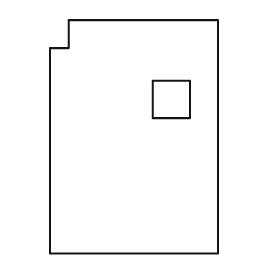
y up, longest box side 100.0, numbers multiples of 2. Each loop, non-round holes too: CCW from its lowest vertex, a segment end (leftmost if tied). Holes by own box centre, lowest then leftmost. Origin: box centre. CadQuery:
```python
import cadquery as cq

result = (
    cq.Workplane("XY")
    .moveTo(-36.0, -50.0)
    .lineTo(36.0, -50.0)
    .lineTo(36.0, 50.0)
    .lineTo(-28.0, 50.0)
    .lineTo(-28.0, 38.0)
    .lineTo(-36.0, 38.0)
    .close()
    .moveTo(8.0, 8.0)
    .lineTo(24.0, 8.0)
    .lineTo(24.0, 24.0)
    .lineTo(8.0, 24.0)
    .close()
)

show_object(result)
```